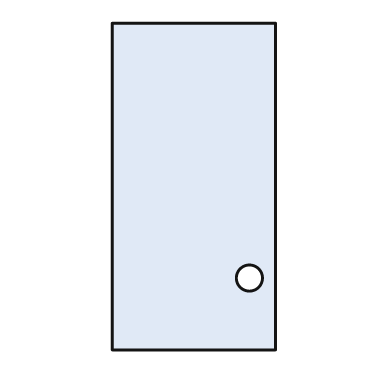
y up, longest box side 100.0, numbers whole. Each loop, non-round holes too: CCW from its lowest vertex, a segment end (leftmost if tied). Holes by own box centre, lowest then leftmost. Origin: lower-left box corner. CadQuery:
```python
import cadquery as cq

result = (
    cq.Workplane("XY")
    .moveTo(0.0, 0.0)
    .lineTo(50.0, 0.0)
    .lineTo(50.0, 100.0)
    .lineTo(0.0, 100.0)
    .close()
    .moveTo(42.0, 22.0)
    .circle(4.0)
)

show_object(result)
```